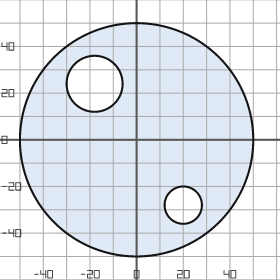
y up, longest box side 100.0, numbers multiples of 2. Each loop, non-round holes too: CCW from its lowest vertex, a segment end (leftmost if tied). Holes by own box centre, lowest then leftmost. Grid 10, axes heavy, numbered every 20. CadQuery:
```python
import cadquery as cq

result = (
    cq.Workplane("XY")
    .moveTo(0.0, 0.0)
    .circle(50.0)
    .moveTo(20.0, -28.0)
    .circle(8.0)
    .moveTo(-18.0, 24.0)
    .circle(12.0)
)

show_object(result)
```